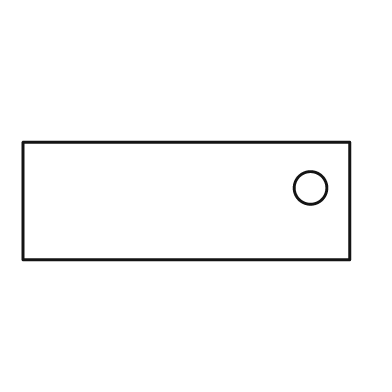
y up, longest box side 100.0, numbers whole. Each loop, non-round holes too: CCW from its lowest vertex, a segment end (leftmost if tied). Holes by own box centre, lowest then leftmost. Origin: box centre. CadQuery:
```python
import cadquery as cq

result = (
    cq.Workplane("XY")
    .moveTo(-50.0, -18.0)
    .lineTo(50.0, -18.0)
    .lineTo(50.0, 18.0)
    .lineTo(-50.0, 18.0)
    .close()
    .moveTo(38.0, 4.0)
    .circle(5.0)
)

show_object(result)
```